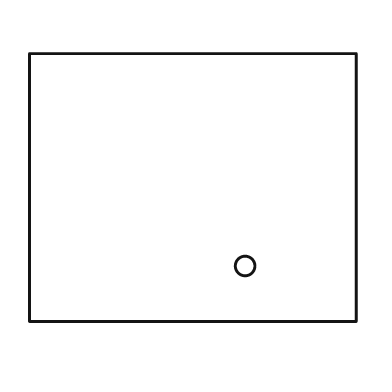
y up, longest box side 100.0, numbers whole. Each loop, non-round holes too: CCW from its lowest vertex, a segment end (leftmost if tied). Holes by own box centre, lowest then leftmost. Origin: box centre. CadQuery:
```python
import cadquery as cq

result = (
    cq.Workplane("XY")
    .moveTo(-50.0, -41.0)
    .lineTo(50.0, -41.0)
    .lineTo(50.0, 41.0)
    .lineTo(-50.0, 41.0)
    .close()
    .moveTo(16.0, -24.0)
    .circle(3.0)
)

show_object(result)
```